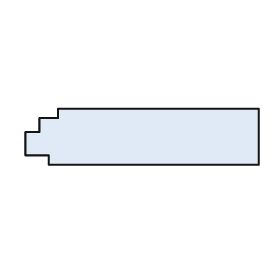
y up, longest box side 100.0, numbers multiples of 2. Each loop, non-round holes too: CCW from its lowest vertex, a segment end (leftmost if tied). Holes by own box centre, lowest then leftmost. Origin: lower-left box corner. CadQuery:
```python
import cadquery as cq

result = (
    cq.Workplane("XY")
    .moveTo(10.0, 0.0)
    .lineTo(100.0, 0.0)
    .lineTo(100.0, 24.0)
    .lineTo(14.0, 24.0)
    .lineTo(14.0, 20.0)
    .lineTo(6.0, 20.0)
    .lineTo(6.0, 14.0)
    .lineTo(0.0, 14.0)
    .lineTo(0.0, 4.0)
    .lineTo(10.0, 4.0)
    .close()
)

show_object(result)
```